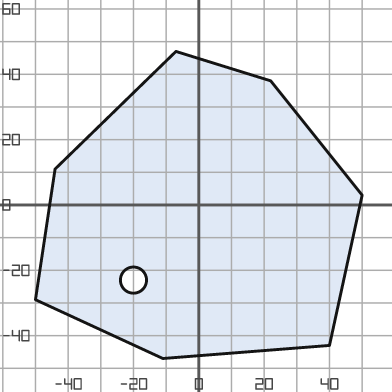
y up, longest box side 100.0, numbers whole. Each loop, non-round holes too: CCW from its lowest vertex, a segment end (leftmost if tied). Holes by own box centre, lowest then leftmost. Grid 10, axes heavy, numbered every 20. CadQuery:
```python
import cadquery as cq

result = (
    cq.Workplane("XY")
    .moveTo(-11.0, -47.0)
    .lineTo(40.0, -43.0)
    .lineTo(50.0, 3.0)
    .lineTo(22.0, 38.0)
    .lineTo(-7.0, 47.0)
    .lineTo(-44.0, 11.0)
    .lineTo(-50.0, -29.0)
    .close()
    .moveTo(-20.0, -23.0)
    .circle(4.0)
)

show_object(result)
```